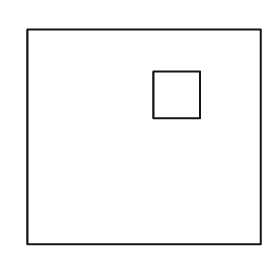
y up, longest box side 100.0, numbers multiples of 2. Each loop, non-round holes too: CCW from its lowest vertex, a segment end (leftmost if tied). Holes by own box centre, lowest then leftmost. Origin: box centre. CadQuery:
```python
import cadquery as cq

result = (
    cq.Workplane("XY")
    .moveTo(-50.0, -46.0)
    .lineTo(50.0, -46.0)
    .lineTo(50.0, 46.0)
    .lineTo(-50.0, 46.0)
    .close()
    .moveTo(4.0, 8.0)
    .lineTo(24.0, 8.0)
    .lineTo(24.0, 28.0)
    .lineTo(4.0, 28.0)
    .close()
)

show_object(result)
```